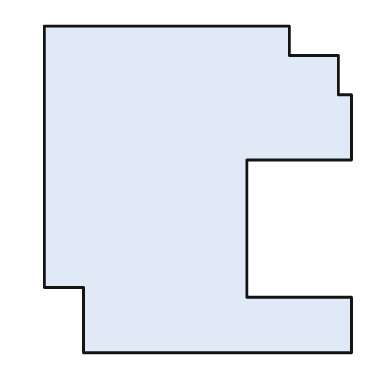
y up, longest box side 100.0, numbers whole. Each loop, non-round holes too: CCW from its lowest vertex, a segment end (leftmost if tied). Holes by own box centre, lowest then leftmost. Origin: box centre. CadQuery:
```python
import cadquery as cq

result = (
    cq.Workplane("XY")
    .moveTo(-35.0, -50.0)
    .lineTo(47.0, -50.0)
    .lineTo(47.0, -33.0)
    .lineTo(15.0, -33.0)
    .lineTo(15.0, 9.0)
    .lineTo(47.0, 9.0)
    .lineTo(47.0, 29.0)
    .lineTo(43.0, 29.0)
    .lineTo(43.0, 41.0)
    .lineTo(28.0, 41.0)
    .lineTo(28.0, 50.0)
    .lineTo(-47.0, 50.0)
    .lineTo(-47.0, -30.0)
    .lineTo(-35.0, -30.0)
    .close()
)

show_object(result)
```